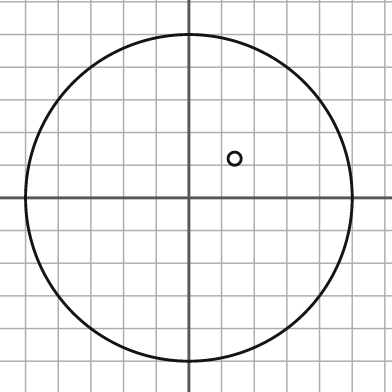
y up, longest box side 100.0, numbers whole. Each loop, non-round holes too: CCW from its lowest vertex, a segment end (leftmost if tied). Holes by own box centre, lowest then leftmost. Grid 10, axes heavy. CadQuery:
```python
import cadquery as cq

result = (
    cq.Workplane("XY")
    .moveTo(0.0, 0.0)
    .circle(50.0)
    .moveTo(14.0, 12.0)
    .circle(2.0)
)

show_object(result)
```